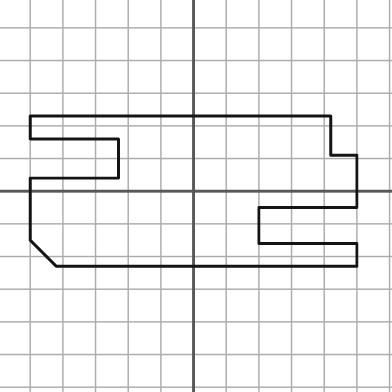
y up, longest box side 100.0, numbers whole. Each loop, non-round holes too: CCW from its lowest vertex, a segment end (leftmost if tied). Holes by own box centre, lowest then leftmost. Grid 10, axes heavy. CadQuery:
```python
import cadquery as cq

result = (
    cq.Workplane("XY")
    .moveTo(-42.0, -23.0)
    .lineTo(50.0, -23.0)
    .lineTo(50.0, -16.0)
    .lineTo(20.0, -16.0)
    .lineTo(20.0, -5.0)
    .lineTo(50.0, -5.0)
    .lineTo(50.0, 11.0)
    .lineTo(42.0, 11.0)
    .lineTo(42.0, 23.0)
    .lineTo(-50.0, 23.0)
    .lineTo(-50.0, 16.0)
    .lineTo(-23.0, 16.0)
    .lineTo(-23.0, 4.0)
    .lineTo(-50.0, 4.0)
    .lineTo(-50.0, -15.0)
    .close()
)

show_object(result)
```